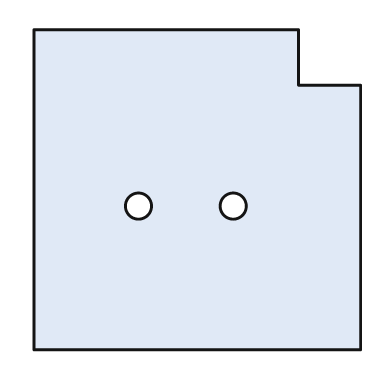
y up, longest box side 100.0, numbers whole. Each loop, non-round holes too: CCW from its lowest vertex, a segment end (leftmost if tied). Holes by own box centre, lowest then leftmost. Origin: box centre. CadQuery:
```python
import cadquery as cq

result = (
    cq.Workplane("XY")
    .moveTo(-50.0, -49.0)
    .lineTo(50.0, -49.0)
    .lineTo(50.0, 32.0)
    .lineTo(31.0, 32.0)
    .lineTo(31.0, 49.0)
    .lineTo(-50.0, 49.0)
    .close()
    .moveTo(-18.0, -5.0)
    .circle(4.0)
    .moveTo(11.0, -5.0)
    .circle(4.0)
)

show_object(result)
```